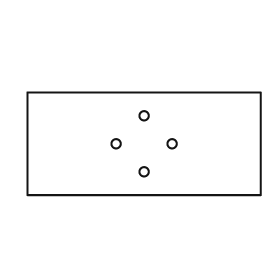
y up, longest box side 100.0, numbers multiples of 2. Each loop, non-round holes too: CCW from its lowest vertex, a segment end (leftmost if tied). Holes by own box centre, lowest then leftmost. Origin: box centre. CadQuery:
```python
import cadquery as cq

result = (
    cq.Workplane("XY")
    .moveTo(-50.0, -22.0)
    .lineTo(50.0, -22.0)
    .lineTo(50.0, 22.0)
    .lineTo(-50.0, 22.0)
    .close()
    .moveTo(0.0, -12.0)
    .circle(2.0)
    .moveTo(-12.0, 0.0)
    .circle(2.0)
    .moveTo(12.0, 0.0)
    .circle(2.0)
    .moveTo(0.0, 12.0)
    .circle(2.0)
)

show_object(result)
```